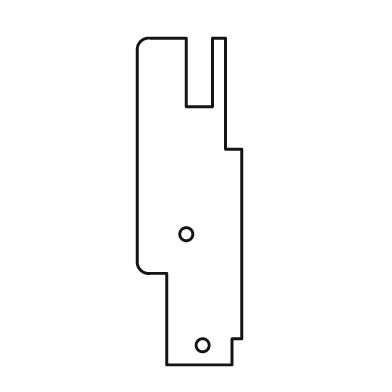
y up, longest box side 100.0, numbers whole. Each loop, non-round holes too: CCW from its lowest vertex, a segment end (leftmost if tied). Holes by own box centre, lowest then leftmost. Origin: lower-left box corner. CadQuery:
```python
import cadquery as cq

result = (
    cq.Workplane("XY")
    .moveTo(9.0, 0.0)
    .lineTo(29.0, 0.0)
    .lineTo(29.0, 8.0)
    .lineTo(32.0, 8.0)
    .lineTo(32.0, 66.0)
    .lineTo(27.0, 66.0)
    .lineTo(27.0, 100.0)
    .lineTo(23.0, 100.0)
    .lineTo(23.0, 79.0)
    .lineTo(15.0, 79.0)
    .lineTo(15.0, 100.0)
    .lineTo(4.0, 100.0)
    .threePointArc((1.0, 99.0), (0.0, 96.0))
    .lineTo(0.0, 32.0)
    .threePointArc((1.0, 29.0), (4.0, 28.0))
    .lineTo(9.0, 28.0)
    .close()
    .moveTo(20.0, 6.0)
    .circle(2.0)
    .moveTo(15.0, 40.0)
    .circle(2.0)
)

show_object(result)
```